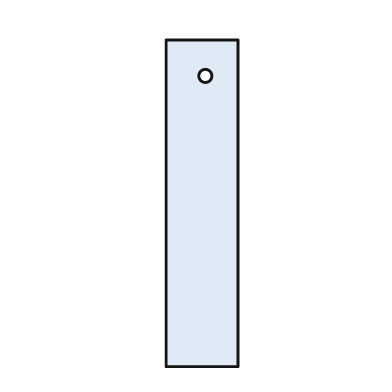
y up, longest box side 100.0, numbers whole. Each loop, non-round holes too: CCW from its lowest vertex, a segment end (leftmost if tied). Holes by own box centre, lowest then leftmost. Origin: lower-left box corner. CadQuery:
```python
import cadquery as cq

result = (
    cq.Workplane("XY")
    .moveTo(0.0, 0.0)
    .lineTo(22.0, 0.0)
    .lineTo(22.0, 100.0)
    .lineTo(0.0, 100.0)
    .close()
    .moveTo(12.0, 89.0)
    .circle(2.0)
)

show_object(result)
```